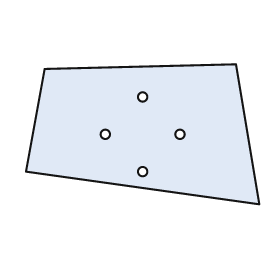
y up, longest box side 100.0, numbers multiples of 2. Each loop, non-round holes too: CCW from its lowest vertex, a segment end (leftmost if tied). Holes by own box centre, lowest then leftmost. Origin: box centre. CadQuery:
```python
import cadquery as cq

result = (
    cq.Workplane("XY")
    .moveTo(50.0, -30.0)
    .lineTo(40.0, 30.0)
    .lineTo(-42.0, 28.0)
    .lineTo(-50.0, -16.0)
    .close()
    .moveTo(0.0, -16.0)
    .circle(2.0)
    .moveTo(-16.0, 0.0)
    .circle(2.0)
    .moveTo(16.0, 0.0)
    .circle(2.0)
    .moveTo(0.0, 16.0)
    .circle(2.0)
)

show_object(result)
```